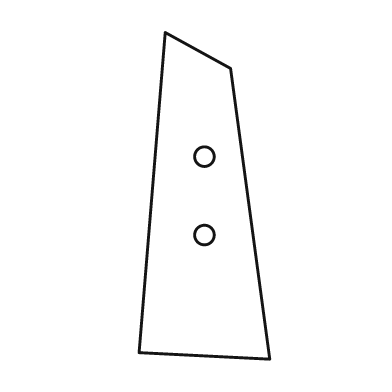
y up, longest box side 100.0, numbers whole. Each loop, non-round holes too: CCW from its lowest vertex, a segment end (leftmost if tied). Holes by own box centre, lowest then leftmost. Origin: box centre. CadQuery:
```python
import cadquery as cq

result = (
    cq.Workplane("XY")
    .moveTo(20.0, -50.0)
    .lineTo(8.0, 39.0)
    .lineTo(-12.0, 50.0)
    .lineTo(-20.0, -48.0)
    .close()
    .moveTo(0.0, -12.0)
    .circle(3.0)
    .moveTo(0.0, 12.0)
    .circle(3.0)
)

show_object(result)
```